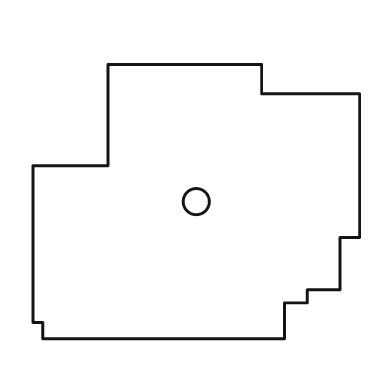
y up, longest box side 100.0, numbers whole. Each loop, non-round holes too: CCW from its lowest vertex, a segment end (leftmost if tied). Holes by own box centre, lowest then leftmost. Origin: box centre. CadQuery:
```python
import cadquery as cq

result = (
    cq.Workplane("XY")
    .moveTo(-47.0, -42.0)
    .lineTo(27.0, -42.0)
    .lineTo(27.0, -31.0)
    .lineTo(34.0, -31.0)
    .lineTo(34.0, -27.0)
    .lineTo(44.0, -27.0)
    .lineTo(44.0, -11.0)
    .lineTo(50.0, -11.0)
    .lineTo(50.0, 33.0)
    .lineTo(20.0, 33.0)
    .lineTo(20.0, 42.0)
    .lineTo(-27.0, 42.0)
    .lineTo(-27.0, 11.0)
    .lineTo(-50.0, 11.0)
    .lineTo(-50.0, -37.0)
    .lineTo(-47.0, -37.0)
    .close()
    .moveTo(0.0, 0.0)
    .circle(4.0)
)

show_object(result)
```